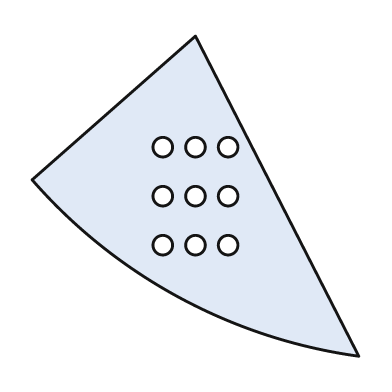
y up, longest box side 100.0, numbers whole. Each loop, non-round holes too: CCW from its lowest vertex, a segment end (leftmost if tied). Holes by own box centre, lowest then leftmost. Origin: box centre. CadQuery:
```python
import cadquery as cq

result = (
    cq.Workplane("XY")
    .moveTo(50.0, -49.0)
    .lineTo(0.0, 49.0)
    .lineTo(-50.0, 5.0)
    .threePointArc((-5.0, -31.0), (50.0, -49.0))
    .close()
    .moveTo(-10.0, -15.0)
    .circle(3.0)
    .moveTo(0.0, -15.0)
    .circle(3.0)
    .moveTo(10.0, -15.0)
    .circle(3.0)
    .moveTo(-10.0, 0.0)
    .circle(3.0)
    .moveTo(0.0, 0.0)
    .circle(3.0)
    .moveTo(10.0, 0.0)
    .circle(3.0)
    .moveTo(-10.0, 15.0)
    .circle(3.0)
    .moveTo(0.0, 15.0)
    .circle(3.0)
    .moveTo(10.0, 15.0)
    .circle(3.0)
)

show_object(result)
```